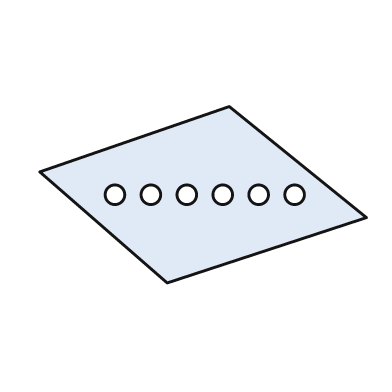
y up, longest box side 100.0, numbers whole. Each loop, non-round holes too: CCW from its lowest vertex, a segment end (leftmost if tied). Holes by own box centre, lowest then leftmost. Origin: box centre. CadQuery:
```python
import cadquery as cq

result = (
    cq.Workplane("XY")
    .moveTo(-11.0, -27.0)
    .lineTo(50.0, -7.0)
    .lineTo(8.0, 27.0)
    .lineTo(-50.0, 7.0)
    .close()
    .moveTo(-27.0, 0.0)
    .circle(3.0)
    .moveTo(-16.0, 0.0)
    .circle(3.0)
    .moveTo(-5.0, 0.0)
    .circle(3.0)
    .moveTo(6.0, 0.0)
    .circle(3.0)
    .moveTo(17.0, 0.0)
    .circle(3.0)
    .moveTo(28.0, 0.0)
    .circle(3.0)
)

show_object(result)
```